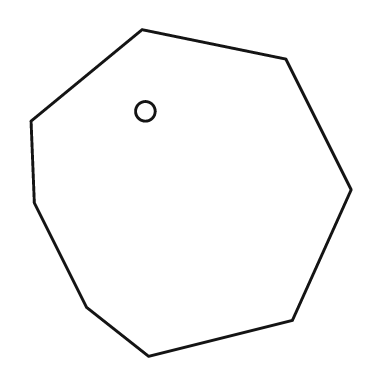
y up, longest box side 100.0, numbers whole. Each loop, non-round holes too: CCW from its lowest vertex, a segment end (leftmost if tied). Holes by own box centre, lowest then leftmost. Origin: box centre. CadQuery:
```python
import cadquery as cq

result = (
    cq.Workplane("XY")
    .moveTo(-13.0, -50.0)
    .lineTo(31.0, -39.0)
    .lineTo(49.0, 1.0)
    .lineTo(29.0, 41.0)
    .lineTo(-15.0, 50.0)
    .lineTo(-49.0, 22.0)
    .lineTo(-48.0, -3.0)
    .lineTo(-32.0, -35.0)
    .close()
    .moveTo(-14.0, 25.0)
    .circle(3.0)
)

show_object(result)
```